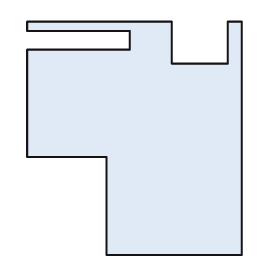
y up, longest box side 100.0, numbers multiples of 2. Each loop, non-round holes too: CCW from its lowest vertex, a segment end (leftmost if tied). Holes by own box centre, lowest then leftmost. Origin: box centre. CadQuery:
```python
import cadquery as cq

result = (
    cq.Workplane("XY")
    .moveTo(-12.0, -50.0)
    .lineTo(46.0, -50.0)
    .lineTo(46.0, 50.0)
    .lineTo(40.0, 50.0)
    .lineTo(40.0, 32.0)
    .lineTo(16.0, 32.0)
    .lineTo(16.0, 50.0)
    .lineTo(-46.0, 50.0)
    .lineTo(-46.0, 46.0)
    .lineTo(-2.0, 46.0)
    .lineTo(-2.0, 38.0)
    .lineTo(-46.0, 38.0)
    .lineTo(-46.0, -8.0)
    .lineTo(-12.0, -8.0)
    .close()
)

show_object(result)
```